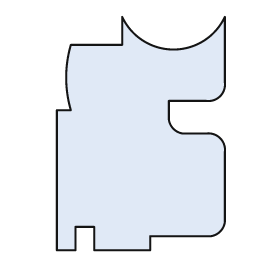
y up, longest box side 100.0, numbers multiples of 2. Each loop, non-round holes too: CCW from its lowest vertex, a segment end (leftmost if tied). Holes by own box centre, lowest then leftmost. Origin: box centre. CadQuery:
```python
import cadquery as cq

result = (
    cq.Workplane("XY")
    .moveTo(-36.0, -50.0)
    .lineTo(-28.0, -50.0)
    .lineTo(-28.0, -40.0)
    .lineTo(-20.0, -40.0)
    .lineTo(-20.0, -50.0)
    .lineTo(4.0, -50.0)
    .lineTo(4.0, -44.0)
    .lineTo(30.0, -44.0)
    .threePointArc((34.0, -42.0), (36.0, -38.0))
    .lineTo(36.0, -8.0)
    .threePointArc((34.0, -2.0), (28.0, 0.0))
    .lineTo(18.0, 0.0)
    .threePointArc((14.0, 2.0), (12.0, 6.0))
    .lineTo(12.0, 14.0)
    .lineTo(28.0, 14.0)
    .threePointArc((34.0, 16.0), (36.0, 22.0))
    .lineTo(36.0, 50.0)
    .threePointArc((14.0, 36.0), (-8.0, 50.0))
    .lineTo(-8.0, 38.0)
    .lineTo(-30.0, 38.0)
    .threePointArc((-32.0, 24.0), (-30.0, 10.0))
    .lineTo(-36.0, 10.0)
    .close()
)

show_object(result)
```